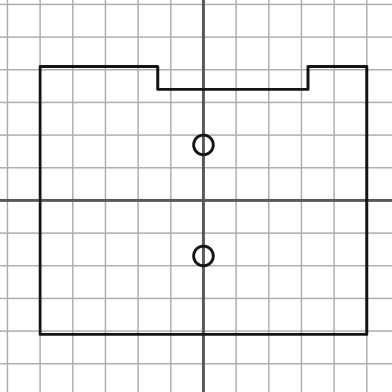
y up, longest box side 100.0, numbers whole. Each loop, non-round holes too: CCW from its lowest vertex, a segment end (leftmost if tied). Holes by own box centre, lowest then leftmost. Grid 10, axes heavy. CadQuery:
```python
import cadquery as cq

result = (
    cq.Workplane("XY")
    .moveTo(-50.0, -41.0)
    .lineTo(50.0, -41.0)
    .lineTo(50.0, 41.0)
    .lineTo(32.0, 41.0)
    .lineTo(32.0, 34.0)
    .lineTo(-14.0, 34.0)
    .lineTo(-14.0, 41.0)
    .lineTo(-50.0, 41.0)
    .close()
    .moveTo(0.0, -17.0)
    .circle(3.0)
    .moveTo(0.0, 17.0)
    .circle(3.0)
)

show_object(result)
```